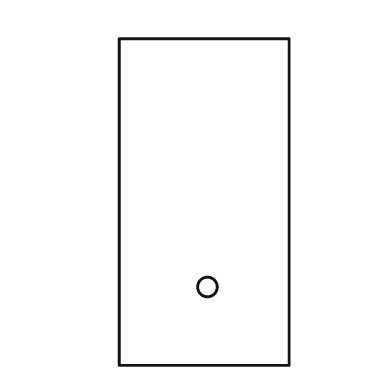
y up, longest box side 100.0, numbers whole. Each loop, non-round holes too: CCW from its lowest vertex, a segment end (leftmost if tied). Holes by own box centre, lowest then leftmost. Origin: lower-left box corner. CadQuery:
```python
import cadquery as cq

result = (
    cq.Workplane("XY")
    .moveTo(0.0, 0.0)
    .lineTo(52.0, 0.0)
    .lineTo(52.0, 100.0)
    .lineTo(0.0, 100.0)
    .close()
    .moveTo(27.0, 24.0)
    .circle(3.0)
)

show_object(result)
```